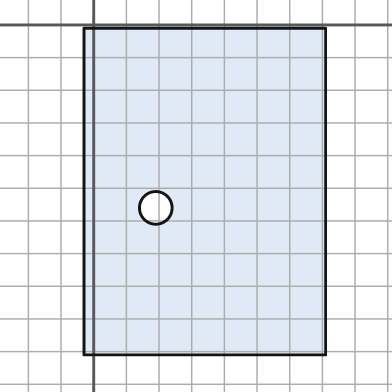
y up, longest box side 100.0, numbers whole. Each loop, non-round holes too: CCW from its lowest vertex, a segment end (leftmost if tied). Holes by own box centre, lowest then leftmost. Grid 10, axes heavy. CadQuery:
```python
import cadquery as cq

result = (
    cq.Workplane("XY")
    .moveTo(-3.0, -101.0)
    .lineTo(71.0, -101.0)
    .lineTo(71.0, -1.0)
    .lineTo(-3.0, -1.0)
    .close()
    .moveTo(19.0, -56.0)
    .circle(5.0)
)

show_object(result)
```